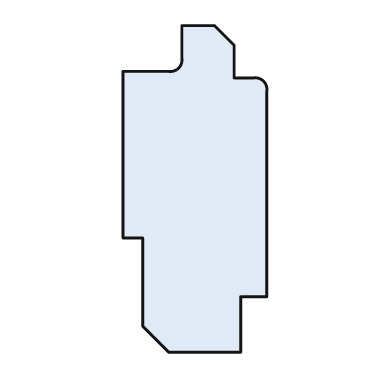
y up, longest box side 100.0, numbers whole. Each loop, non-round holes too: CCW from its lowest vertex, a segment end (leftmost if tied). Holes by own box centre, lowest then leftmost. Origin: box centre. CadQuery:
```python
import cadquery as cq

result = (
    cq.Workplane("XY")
    .moveTo(-8.0, -50.0)
    .lineTo(14.0, -50.0)
    .lineTo(14.0, -33.0)
    .lineTo(22.0, -33.0)
    .lineTo(22.0, 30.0)
    .threePointArc((21.0, 33.0), (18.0, 34.0))
    .lineTo(12.0, 34.0)
    .lineTo(12.0, 44.0)
    .lineTo(6.0, 50.0)
    .lineTo(-4.0, 50.0)
    .lineTo(-4.0, 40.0)
    .threePointArc((-5.0, 37.0), (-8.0, 36.0))
    .lineTo(-22.0, 36.0)
    .lineTo(-22.0, -15.0)
    .lineTo(-16.0, -15.0)
    .lineTo(-16.0, -42.0)
    .close()
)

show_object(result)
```